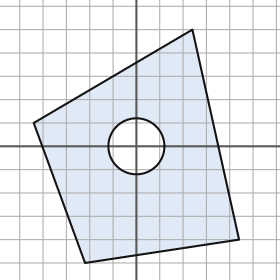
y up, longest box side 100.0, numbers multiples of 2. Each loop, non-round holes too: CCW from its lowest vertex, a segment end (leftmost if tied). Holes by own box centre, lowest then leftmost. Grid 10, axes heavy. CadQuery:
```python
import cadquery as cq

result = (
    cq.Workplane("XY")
    .moveTo(-22.0, -50.0)
    .lineTo(44.0, -40.0)
    .lineTo(24.0, 50.0)
    .lineTo(-44.0, 10.0)
    .close()
    .moveTo(0.0, 0.0)
    .circle(12.0)
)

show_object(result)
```